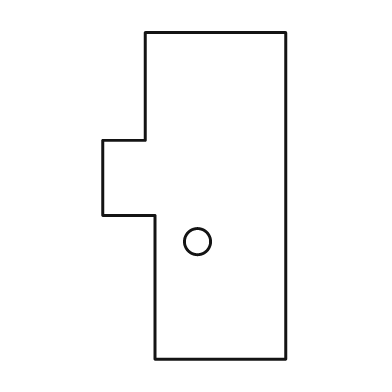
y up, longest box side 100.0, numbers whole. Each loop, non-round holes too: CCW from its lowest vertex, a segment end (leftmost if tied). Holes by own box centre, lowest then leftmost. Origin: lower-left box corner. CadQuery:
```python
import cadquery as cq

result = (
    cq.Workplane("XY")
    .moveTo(16.0, 0.0)
    .lineTo(56.0, 0.0)
    .lineTo(56.0, 100.0)
    .lineTo(13.0, 100.0)
    .lineTo(13.0, 67.0)
    .lineTo(0.0, 67.0)
    .lineTo(0.0, 44.0)
    .lineTo(16.0, 44.0)
    .close()
    .moveTo(29.0, 36.0)
    .circle(4.0)
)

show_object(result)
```